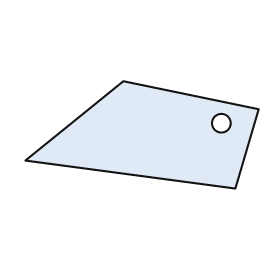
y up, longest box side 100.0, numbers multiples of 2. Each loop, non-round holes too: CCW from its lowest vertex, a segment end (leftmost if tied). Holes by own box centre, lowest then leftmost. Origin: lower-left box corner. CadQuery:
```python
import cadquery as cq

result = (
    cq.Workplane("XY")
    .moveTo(90.0, 0.0)
    .lineTo(100.0, 34.0)
    .lineTo(42.0, 46.0)
    .lineTo(0.0, 12.0)
    .close()
    .moveTo(84.0, 28.0)
    .circle(4.0)
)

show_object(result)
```